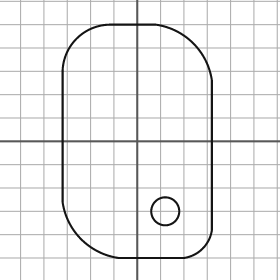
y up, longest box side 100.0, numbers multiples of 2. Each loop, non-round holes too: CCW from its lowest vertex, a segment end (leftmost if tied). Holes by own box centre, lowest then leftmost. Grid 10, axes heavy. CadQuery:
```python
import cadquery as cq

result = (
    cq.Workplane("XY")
    .moveTo(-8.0, -50.0)
    .lineTo(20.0, -50.0)
    .threePointArc((28.0, -46.0), (32.0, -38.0))
    .lineTo(32.0, 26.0)
    .threePointArc((24.0, 42.0), (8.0, 50.0))
    .lineTo(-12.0, 50.0)
    .threePointArc((-26.0, 44.0), (-32.0, 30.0))
    .lineTo(-32.0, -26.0)
    .threePointArc((-24.0, -42.0), (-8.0, -50.0))
    .close()
    .moveTo(12.0, -30.0)
    .circle(6.0)
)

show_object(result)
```